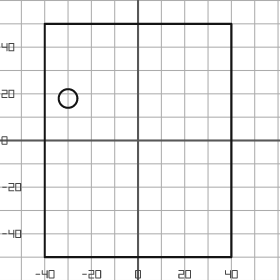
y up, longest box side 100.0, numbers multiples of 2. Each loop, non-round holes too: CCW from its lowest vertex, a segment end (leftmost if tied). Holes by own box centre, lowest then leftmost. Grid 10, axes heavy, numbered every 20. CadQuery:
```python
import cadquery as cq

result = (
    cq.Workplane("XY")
    .moveTo(-40.0, -50.0)
    .lineTo(40.0, -50.0)
    .lineTo(40.0, 50.0)
    .lineTo(-40.0, 50.0)
    .close()
    .moveTo(-30.0, 18.0)
    .circle(4.0)
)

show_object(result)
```